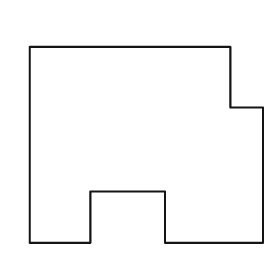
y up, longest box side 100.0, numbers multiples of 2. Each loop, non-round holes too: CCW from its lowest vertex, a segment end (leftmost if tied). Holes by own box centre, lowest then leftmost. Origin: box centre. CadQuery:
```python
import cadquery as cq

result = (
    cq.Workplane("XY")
    .moveTo(-50.0, -42.0)
    .lineTo(-24.0, -42.0)
    .lineTo(-24.0, -20.0)
    .lineTo(8.0, -20.0)
    .lineTo(8.0, -42.0)
    .lineTo(50.0, -42.0)
    .lineTo(50.0, 16.0)
    .lineTo(36.0, 16.0)
    .lineTo(36.0, 42.0)
    .lineTo(-50.0, 42.0)
    .close()
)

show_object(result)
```